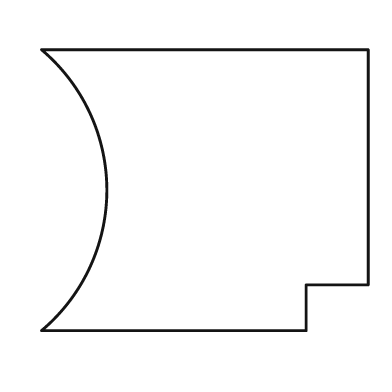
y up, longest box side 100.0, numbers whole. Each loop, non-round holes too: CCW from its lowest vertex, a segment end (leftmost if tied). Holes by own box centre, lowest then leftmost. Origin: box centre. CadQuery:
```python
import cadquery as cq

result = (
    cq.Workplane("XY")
    .moveTo(-50.0, -43.0)
    .lineTo(31.0, -43.0)
    .lineTo(31.0, -29.0)
    .lineTo(50.0, -29.0)
    .lineTo(50.0, 43.0)
    .lineTo(-50.0, 43.0)
    .threePointArc((-30.0, 0.0), (-50.0, -43.0))
    .close()
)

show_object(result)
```